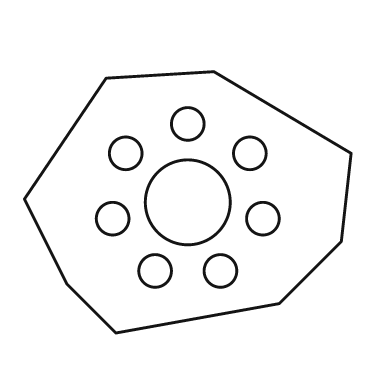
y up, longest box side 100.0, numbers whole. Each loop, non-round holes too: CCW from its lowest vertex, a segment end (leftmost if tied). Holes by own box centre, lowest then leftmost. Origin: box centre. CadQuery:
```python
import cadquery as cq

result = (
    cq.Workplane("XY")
    .moveTo(-22.0, -40.0)
    .lineTo(28.0, -31.0)
    .lineTo(47.0, -12.0)
    .lineTo(50.0, 15.0)
    .lineTo(8.0, 40.0)
    .lineTo(-25.0, 38.0)
    .lineTo(-50.0, 1.0)
    .lineTo(-37.0, -25.0)
    .close()
    .moveTo(-10.0, -21.0)
    .circle(5.0)
    .moveTo(10.0, -21.0)
    .circle(5.0)
    .moveTo(-23.0, -5.0)
    .circle(5.0)
    .moveTo(23.0, -5.0)
    .circle(5.0)
    .moveTo(0.0, 0.0)
    .circle(13.0)
    .moveTo(-19.0, 15.0)
    .circle(5.0)
    .moveTo(19.0, 15.0)
    .circle(5.0)
    .moveTo(0.0, 24.0)
    .circle(5.0)
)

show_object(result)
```